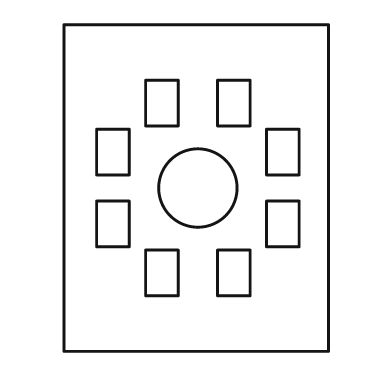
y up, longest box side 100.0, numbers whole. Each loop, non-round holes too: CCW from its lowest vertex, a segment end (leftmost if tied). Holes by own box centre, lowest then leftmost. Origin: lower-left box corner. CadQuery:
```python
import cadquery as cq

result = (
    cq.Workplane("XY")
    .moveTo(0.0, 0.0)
    .lineTo(81.0, 0.0)
    .lineTo(81.0, 100.0)
    .lineTo(0.0, 100.0)
    .close()
    .moveTo(25.0, 17.0)
    .lineTo(35.0, 17.0)
    .lineTo(35.0, 31.0)
    .lineTo(25.0, 31.0)
    .close()
    .moveTo(47.0, 17.0)
    .lineTo(57.0, 17.0)
    .lineTo(57.0, 31.0)
    .lineTo(47.0, 31.0)
    .close()
    .moveTo(10.0, 32.0)
    .lineTo(20.0, 32.0)
    .lineTo(20.0, 46.0)
    .lineTo(10.0, 46.0)
    .close()
    .moveTo(62.0, 32.0)
    .lineTo(72.0, 32.0)
    .lineTo(72.0, 46.0)
    .lineTo(62.0, 46.0)
    .close()
    .moveTo(41.0, 50.0)
    .circle(12.0)
    .moveTo(10.0, 54.0)
    .lineTo(20.0, 54.0)
    .lineTo(20.0, 68.0)
    .lineTo(10.0, 68.0)
    .close()
    .moveTo(62.0, 54.0)
    .lineTo(72.0, 54.0)
    .lineTo(72.0, 68.0)
    .lineTo(62.0, 68.0)
    .close()
    .moveTo(25.0, 69.0)
    .lineTo(35.0, 69.0)
    .lineTo(35.0, 83.0)
    .lineTo(25.0, 83.0)
    .close()
    .moveTo(47.0, 69.0)
    .lineTo(57.0, 69.0)
    .lineTo(57.0, 83.0)
    .lineTo(47.0, 83.0)
    .close()
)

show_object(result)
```